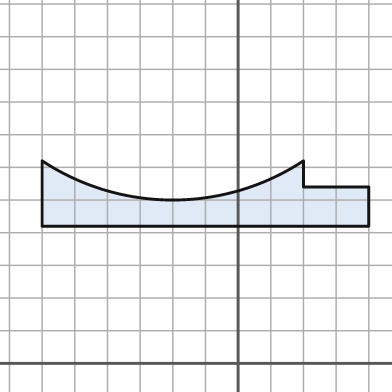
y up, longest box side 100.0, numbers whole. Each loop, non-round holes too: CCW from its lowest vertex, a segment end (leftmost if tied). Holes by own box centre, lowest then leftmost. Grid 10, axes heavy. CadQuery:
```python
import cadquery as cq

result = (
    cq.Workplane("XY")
    .moveTo(-60.0, 42.0)
    .lineTo(40.0, 42.0)
    .lineTo(40.0, 54.0)
    .lineTo(20.0, 54.0)
    .lineTo(20.0, 62.0)
    .threePointArc((-20.0, 50.0), (-60.0, 62.0))
    .close()
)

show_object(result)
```